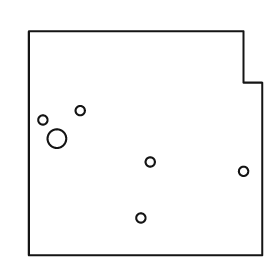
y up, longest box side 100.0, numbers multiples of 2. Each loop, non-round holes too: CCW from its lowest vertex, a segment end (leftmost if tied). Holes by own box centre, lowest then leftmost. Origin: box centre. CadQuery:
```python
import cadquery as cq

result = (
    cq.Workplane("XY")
    .moveTo(-50.0, -48.0)
    .lineTo(50.0, -48.0)
    .lineTo(50.0, 26.0)
    .lineTo(42.0, 26.0)
    .lineTo(42.0, 48.0)
    .lineTo(-50.0, 48.0)
    .close()
    .moveTo(-2.0, -32.0)
    .circle(2.0)
    .moveTo(42.0, -12.0)
    .circle(2.0)
    .moveTo(2.0, -8.0)
    .circle(2.0)
    .moveTo(-38.0, 2.0)
    .circle(4.0)
    .moveTo(-44.0, 10.0)
    .circle(2.0)
    .moveTo(-28.0, 14.0)
    .circle(2.0)
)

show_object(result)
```